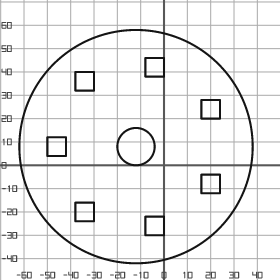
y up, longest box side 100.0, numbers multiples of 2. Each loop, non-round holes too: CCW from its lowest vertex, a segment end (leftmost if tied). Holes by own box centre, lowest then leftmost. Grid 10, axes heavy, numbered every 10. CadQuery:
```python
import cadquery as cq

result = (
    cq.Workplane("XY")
    .moveTo(-12.0, 8.0)
    .circle(50.0)
    .moveTo(-8.0, -30.0)
    .lineTo(0.0, -30.0)
    .lineTo(0.0, -22.0)
    .lineTo(-8.0, -22.0)
    .close()
    .moveTo(-38.0, -24.0)
    .lineTo(-30.0, -24.0)
    .lineTo(-30.0, -16.0)
    .lineTo(-38.0, -16.0)
    .close()
    .moveTo(16.0, -12.0)
    .lineTo(24.0, -12.0)
    .lineTo(24.0, -4.0)
    .lineTo(16.0, -4.0)
    .close()
    .moveTo(-50.0, 4.0)
    .lineTo(-42.0, 4.0)
    .lineTo(-42.0, 12.0)
    .lineTo(-50.0, 12.0)
    .close()
    .moveTo(-12.0, 8.0)
    .circle(8.0)
    .moveTo(16.0, 20.0)
    .lineTo(24.0, 20.0)
    .lineTo(24.0, 28.0)
    .lineTo(16.0, 28.0)
    .close()
    .moveTo(-38.0, 32.0)
    .lineTo(-30.0, 32.0)
    .lineTo(-30.0, 40.0)
    .lineTo(-38.0, 40.0)
    .close()
    .moveTo(-8.0, 38.0)
    .lineTo(0.0, 38.0)
    .lineTo(0.0, 46.0)
    .lineTo(-8.0, 46.0)
    .close()
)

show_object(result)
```